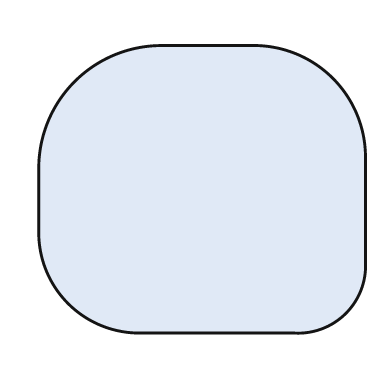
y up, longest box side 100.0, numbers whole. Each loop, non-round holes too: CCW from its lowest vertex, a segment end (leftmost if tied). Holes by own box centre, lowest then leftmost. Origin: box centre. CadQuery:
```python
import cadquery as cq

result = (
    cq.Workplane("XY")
    .moveTo(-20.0, -44.0)
    .lineTo(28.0, -44.0)
    .threePointArc((44.0, -38.0), (50.0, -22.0))
    .lineTo(50.0, 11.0)
    .threePointArc((40.0, 34.0), (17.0, 44.0))
    .lineTo(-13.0, 44.0)
    .threePointArc((-39.0, 33.0), (-50.0, 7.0))
    .lineTo(-50.0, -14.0)
    .threePointArc((-41.0, -35.0), (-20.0, -44.0))
    .close()
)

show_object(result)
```